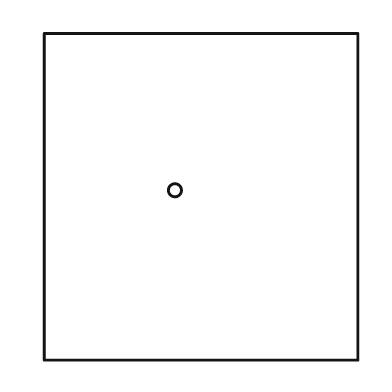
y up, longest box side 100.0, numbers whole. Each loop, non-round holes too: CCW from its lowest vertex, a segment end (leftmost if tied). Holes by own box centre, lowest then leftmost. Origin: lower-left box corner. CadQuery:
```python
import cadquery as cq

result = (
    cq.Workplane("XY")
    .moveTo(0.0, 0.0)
    .lineTo(96.0, 0.0)
    .lineTo(96.0, 100.0)
    .lineTo(0.0, 100.0)
    .close()
    .moveTo(40.0, 52.0)
    .circle(2.0)
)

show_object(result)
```